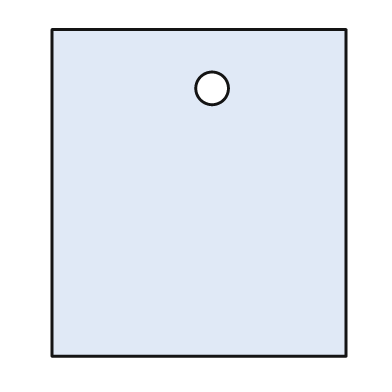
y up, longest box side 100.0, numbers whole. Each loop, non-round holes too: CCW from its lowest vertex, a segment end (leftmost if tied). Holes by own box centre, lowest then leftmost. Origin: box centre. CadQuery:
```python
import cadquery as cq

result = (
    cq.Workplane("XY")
    .moveTo(-45.0, -50.0)
    .lineTo(45.0, -50.0)
    .lineTo(45.0, 50.0)
    .lineTo(-45.0, 50.0)
    .close()
    .moveTo(4.0, 32.0)
    .circle(5.0)
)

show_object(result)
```